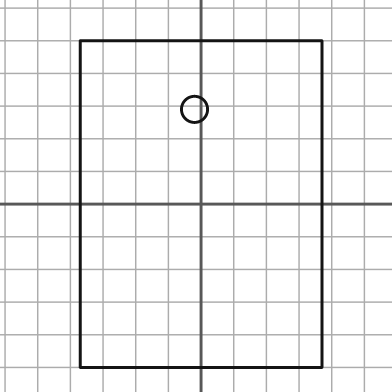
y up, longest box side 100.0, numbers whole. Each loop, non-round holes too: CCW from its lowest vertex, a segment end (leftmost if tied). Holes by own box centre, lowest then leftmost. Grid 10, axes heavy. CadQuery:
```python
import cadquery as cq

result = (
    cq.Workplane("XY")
    .moveTo(-37.0, -50.0)
    .lineTo(37.0, -50.0)
    .lineTo(37.0, 50.0)
    .lineTo(-37.0, 50.0)
    .close()
    .moveTo(-2.0, 29.0)
    .circle(4.0)
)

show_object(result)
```